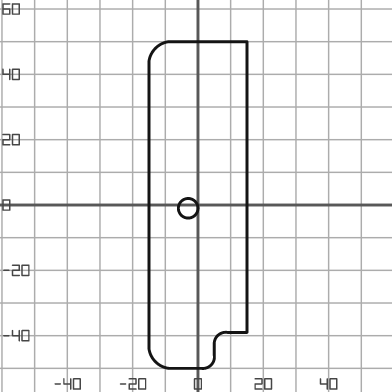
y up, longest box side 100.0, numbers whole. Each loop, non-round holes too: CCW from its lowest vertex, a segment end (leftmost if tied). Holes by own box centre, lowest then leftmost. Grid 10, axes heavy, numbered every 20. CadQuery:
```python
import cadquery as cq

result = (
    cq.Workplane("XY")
    .moveTo(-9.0, -50.0)
    .lineTo(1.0, -50.0)
    .threePointArc((4.0, -49.0), (5.0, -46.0))
    .lineTo(5.0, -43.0)
    .threePointArc((6.0, -40.0), (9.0, -39.0))
    .lineTo(15.0, -39.0)
    .lineTo(15.0, 50.0)
    .lineTo(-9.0, 50.0)
    .threePointArc((-13.0, 48.0), (-15.0, 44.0))
    .lineTo(-15.0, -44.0)
    .threePointArc((-13.0, -48.0), (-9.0, -50.0))
    .close()
    .moveTo(-3.0, -1.0)
    .circle(3.0)
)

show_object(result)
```